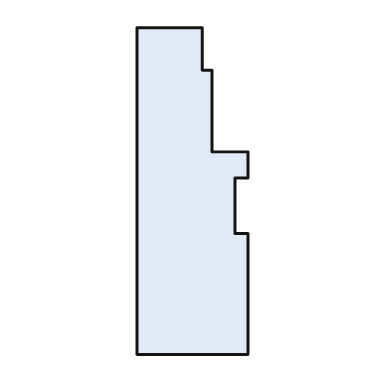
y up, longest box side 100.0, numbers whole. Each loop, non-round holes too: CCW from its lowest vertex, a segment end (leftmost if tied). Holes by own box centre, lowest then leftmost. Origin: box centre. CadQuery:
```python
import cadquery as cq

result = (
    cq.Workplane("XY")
    .moveTo(-17.0, -50.0)
    .lineTo(17.0, -50.0)
    .lineTo(17.0, -13.0)
    .lineTo(13.0, -13.0)
    .lineTo(13.0, 4.0)
    .lineTo(17.0, 4.0)
    .lineTo(17.0, 12.0)
    .lineTo(6.0, 12.0)
    .lineTo(6.0, 37.0)
    .lineTo(3.0, 37.0)
    .lineTo(3.0, 50.0)
    .lineTo(-17.0, 50.0)
    .close()
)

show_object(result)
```